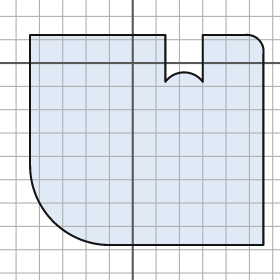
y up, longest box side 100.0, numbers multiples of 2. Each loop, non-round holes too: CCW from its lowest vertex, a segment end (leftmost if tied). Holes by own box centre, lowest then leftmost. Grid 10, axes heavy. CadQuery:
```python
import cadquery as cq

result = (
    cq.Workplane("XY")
    .moveTo(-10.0, -78.0)
    .lineTo(56.0, -78.0)
    .lineTo(56.0, 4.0)
    .threePointArc((54.0, 10.0), (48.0, 12.0))
    .lineTo(30.0, 12.0)
    .lineTo(30.0, -8.0)
    .threePointArc((22.0, -4.0), (14.0, -8.0))
    .lineTo(14.0, 12.0)
    .lineTo(-44.0, 12.0)
    .lineTo(-44.0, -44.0)
    .threePointArc((-34.0, -68.0), (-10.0, -78.0))
    .close()
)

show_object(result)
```